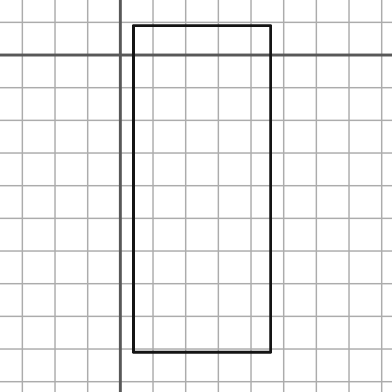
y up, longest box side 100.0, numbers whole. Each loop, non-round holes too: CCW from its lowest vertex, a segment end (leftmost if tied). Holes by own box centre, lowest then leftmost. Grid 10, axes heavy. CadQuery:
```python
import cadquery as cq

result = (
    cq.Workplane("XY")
    .moveTo(4.0, -91.0)
    .lineTo(46.0, -91.0)
    .lineTo(46.0, 9.0)
    .lineTo(4.0, 9.0)
    .close()
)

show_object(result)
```